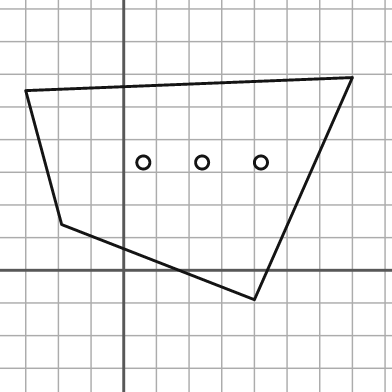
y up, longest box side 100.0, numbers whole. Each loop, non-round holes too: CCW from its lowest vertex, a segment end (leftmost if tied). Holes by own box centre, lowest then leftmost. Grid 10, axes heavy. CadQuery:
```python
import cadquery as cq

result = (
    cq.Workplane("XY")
    .moveTo(40.0, -9.0)
    .lineTo(70.0, 59.0)
    .lineTo(-30.0, 55.0)
    .lineTo(-19.0, 14.0)
    .close()
    .moveTo(6.0, 33.0)
    .circle(2.0)
    .moveTo(24.0, 33.0)
    .circle(2.0)
    .moveTo(42.0, 33.0)
    .circle(2.0)
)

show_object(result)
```